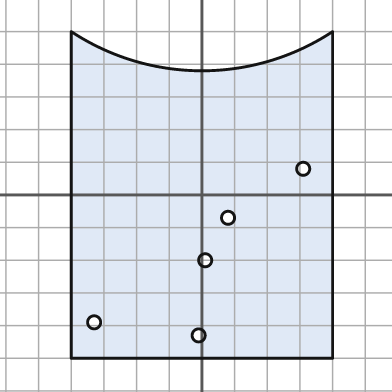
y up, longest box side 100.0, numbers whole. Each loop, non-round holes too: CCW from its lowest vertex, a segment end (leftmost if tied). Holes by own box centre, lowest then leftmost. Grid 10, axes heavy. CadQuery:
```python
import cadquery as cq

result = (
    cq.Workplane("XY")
    .moveTo(-40.0, -50.0)
    .lineTo(40.0, -50.0)
    .lineTo(40.0, 50.0)
    .threePointArc((0.0, 38.0), (-40.0, 50.0))
    .close()
    .moveTo(-1.0, -43.0)
    .circle(2.0)
    .moveTo(-33.0, -39.0)
    .circle(2.0)
    .moveTo(1.0, -20.0)
    .circle(2.0)
    .moveTo(8.0, -7.0)
    .circle(2.0)
    .moveTo(31.0, 8.0)
    .circle(2.0)
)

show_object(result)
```